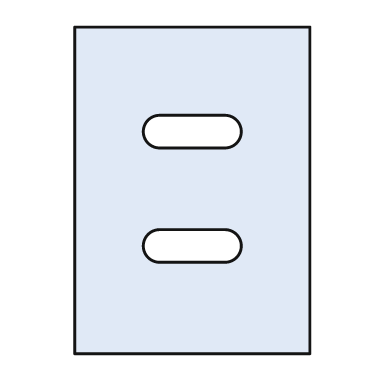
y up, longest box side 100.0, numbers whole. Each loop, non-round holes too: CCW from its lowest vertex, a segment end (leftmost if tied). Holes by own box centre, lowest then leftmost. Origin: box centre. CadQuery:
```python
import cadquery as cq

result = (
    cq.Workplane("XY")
    .moveTo(-36.0, -50.0)
    .lineTo(36.0, -50.0)
    .lineTo(36.0, 50.0)
    .lineTo(-36.0, 50.0)
    .close()
    .moveTo(-10.0, -22.0)
    .lineTo(10.0, -22.0)
    .threePointArc((15.0, -17.0), (10.0, -12.0))
    .lineTo(-10.0, -12.0)
    .threePointArc((-15.0, -17.0), (-10.0, -22.0))
    .close()
    .moveTo(-10.0, 13.0)
    .lineTo(10.0, 13.0)
    .threePointArc((15.0, 18.0), (10.0, 23.0))
    .lineTo(-10.0, 23.0)
    .threePointArc((-15.0, 18.0), (-10.0, 13.0))
    .close()
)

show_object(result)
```